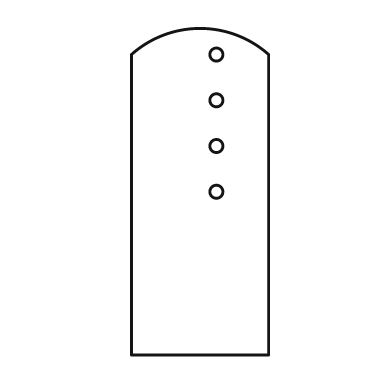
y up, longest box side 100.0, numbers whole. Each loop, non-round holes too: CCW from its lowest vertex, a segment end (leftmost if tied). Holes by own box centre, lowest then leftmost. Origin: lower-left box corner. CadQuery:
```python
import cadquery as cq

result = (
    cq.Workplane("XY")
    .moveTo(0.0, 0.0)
    .lineTo(42.0, 0.0)
    .lineTo(42.0, 92.0)
    .threePointArc((21.0, 100.0), (0.0, 92.0))
    .close()
    .moveTo(26.0, 50.0)
    .circle(2.0)
    .moveTo(26.0, 64.0)
    .circle(2.0)
    .moveTo(26.0, 78.0)
    .circle(2.0)
    .moveTo(26.0, 92.0)
    .circle(2.0)
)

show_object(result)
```